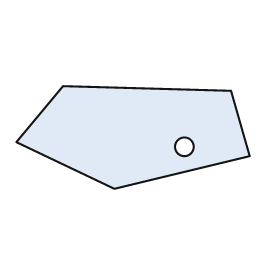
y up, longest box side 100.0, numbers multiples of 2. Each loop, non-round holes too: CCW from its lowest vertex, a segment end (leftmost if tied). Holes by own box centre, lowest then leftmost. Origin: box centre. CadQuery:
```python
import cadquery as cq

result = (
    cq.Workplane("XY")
    .moveTo(-8.0, -22.0)
    .lineTo(50.0, -8.0)
    .lineTo(42.0, 20.0)
    .lineTo(-30.0, 22.0)
    .lineTo(-50.0, -2.0)
    .close()
    .moveTo(22.0, -4.0)
    .circle(4.0)
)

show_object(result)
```